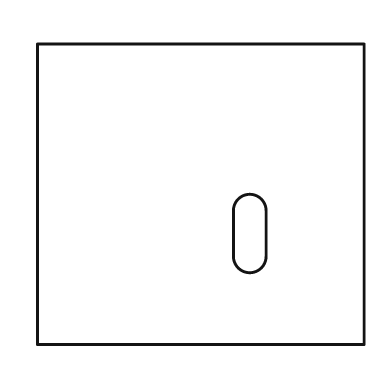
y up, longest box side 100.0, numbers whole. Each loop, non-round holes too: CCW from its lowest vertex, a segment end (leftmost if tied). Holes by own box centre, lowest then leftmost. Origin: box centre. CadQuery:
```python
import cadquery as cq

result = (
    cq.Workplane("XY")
    .moveTo(-50.0, -46.0)
    .lineTo(50.0, -46.0)
    .lineTo(50.0, 46.0)
    .lineTo(-50.0, 46.0)
    .close()
    .moveTo(10.0, -19.0)
    .threePointArc((15.0, -24.0), (20.0, -19.0))
    .lineTo(20.0, -5.0)
    .threePointArc((15.0, 0.0), (10.0, -5.0))
    .close()
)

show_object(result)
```